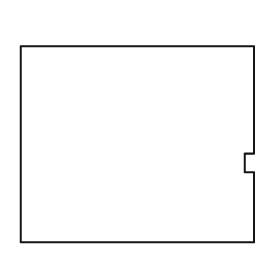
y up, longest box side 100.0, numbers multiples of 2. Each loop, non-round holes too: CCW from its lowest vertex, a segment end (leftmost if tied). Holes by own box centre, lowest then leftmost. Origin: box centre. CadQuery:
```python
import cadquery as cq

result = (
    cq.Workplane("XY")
    .moveTo(-50.0, -42.0)
    .lineTo(50.0, -42.0)
    .lineTo(50.0, -12.0)
    .lineTo(46.0, -12.0)
    .lineTo(46.0, -4.0)
    .lineTo(50.0, -4.0)
    .lineTo(50.0, 42.0)
    .lineTo(-50.0, 42.0)
    .close()
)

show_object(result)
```